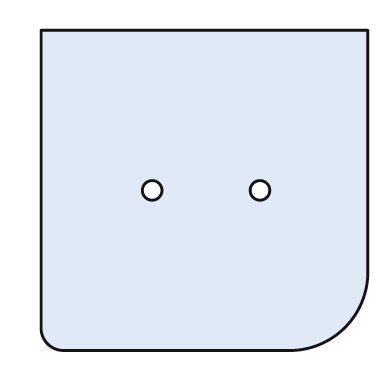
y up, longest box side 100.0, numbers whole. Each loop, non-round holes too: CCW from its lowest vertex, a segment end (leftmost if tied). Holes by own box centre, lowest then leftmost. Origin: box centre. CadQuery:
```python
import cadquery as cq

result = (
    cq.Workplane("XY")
    .moveTo(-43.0, -49.0)
    .lineTo(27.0, -49.0)
    .threePointArc((43.0, -42.0), (50.0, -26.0))
    .lineTo(50.0, 49.0)
    .lineTo(-50.0, 49.0)
    .lineTo(-50.0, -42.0)
    .threePointArc((-48.0, -47.0), (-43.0, -49.0))
    .close()
    .moveTo(-16.0, 0.0)
    .circle(3.0)
    .moveTo(17.0, 0.0)
    .circle(3.0)
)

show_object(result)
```